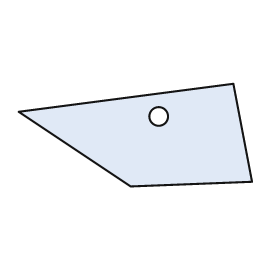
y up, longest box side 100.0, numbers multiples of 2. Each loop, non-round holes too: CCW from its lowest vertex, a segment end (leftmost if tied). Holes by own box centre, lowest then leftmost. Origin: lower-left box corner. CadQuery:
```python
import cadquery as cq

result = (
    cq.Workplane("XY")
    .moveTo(48.0, 0.0)
    .lineTo(100.0, 2.0)
    .lineTo(92.0, 44.0)
    .lineTo(0.0, 32.0)
    .close()
    .moveTo(60.0, 30.0)
    .circle(4.0)
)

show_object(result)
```